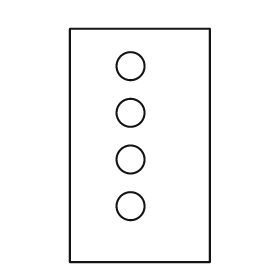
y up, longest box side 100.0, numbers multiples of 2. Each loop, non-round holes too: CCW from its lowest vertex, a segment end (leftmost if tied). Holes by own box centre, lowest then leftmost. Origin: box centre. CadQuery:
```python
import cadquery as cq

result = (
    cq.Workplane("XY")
    .moveTo(-30.0, -50.0)
    .lineTo(30.0, -50.0)
    .lineTo(30.0, 50.0)
    .lineTo(-30.0, 50.0)
    .close()
    .moveTo(-4.0, -26.0)
    .circle(6.0)
    .moveTo(-4.0, -6.0)
    .circle(6.0)
    .moveTo(-4.0, 14.0)
    .circle(6.0)
    .moveTo(-4.0, 34.0)
    .circle(6.0)
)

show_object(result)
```